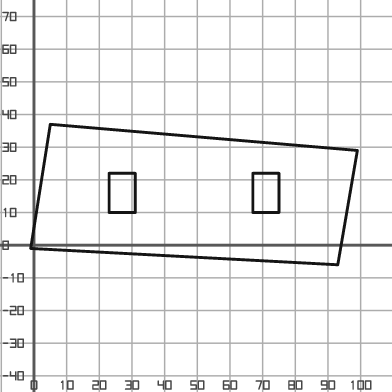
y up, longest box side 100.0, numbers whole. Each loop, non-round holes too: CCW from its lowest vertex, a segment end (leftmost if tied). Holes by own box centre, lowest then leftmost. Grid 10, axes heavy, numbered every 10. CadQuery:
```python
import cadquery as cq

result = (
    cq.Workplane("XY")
    .moveTo(93.0, -6.0)
    .lineTo(99.0, 29.0)
    .lineTo(5.0, 37.0)
    .lineTo(-1.0, -1.0)
    .close()
    .moveTo(23.0, 10.0)
    .lineTo(31.0, 10.0)
    .lineTo(31.0, 22.0)
    .lineTo(23.0, 22.0)
    .close()
    .moveTo(67.0, 10.0)
    .lineTo(75.0, 10.0)
    .lineTo(75.0, 22.0)
    .lineTo(67.0, 22.0)
    .close()
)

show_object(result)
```